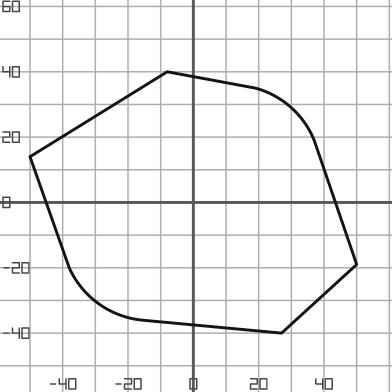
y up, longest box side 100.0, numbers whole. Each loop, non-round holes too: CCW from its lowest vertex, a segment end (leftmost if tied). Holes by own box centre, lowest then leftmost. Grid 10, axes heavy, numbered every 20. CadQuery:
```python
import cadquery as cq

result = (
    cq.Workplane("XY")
    .moveTo(27.0, -40.0)
    .lineTo(50.0, -19.0)
    .lineTo(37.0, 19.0)
    .threePointArc((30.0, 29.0), (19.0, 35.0))
    .lineTo(-8.0, 40.0)
    .lineTo(-50.0, 14.0)
    .lineTo(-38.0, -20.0)
    .threePointArc((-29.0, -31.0), (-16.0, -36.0))
    .close()
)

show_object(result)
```